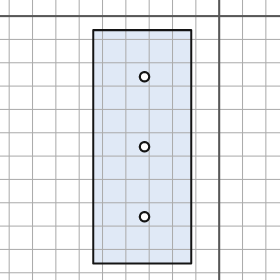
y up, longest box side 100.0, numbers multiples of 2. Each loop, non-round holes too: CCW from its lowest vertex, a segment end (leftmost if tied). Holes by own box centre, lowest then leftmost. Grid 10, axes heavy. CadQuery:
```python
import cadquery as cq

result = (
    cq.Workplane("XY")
    .moveTo(-54.0, -106.0)
    .lineTo(-12.0, -106.0)
    .lineTo(-12.0, -6.0)
    .lineTo(-54.0, -6.0)
    .close()
    .moveTo(-32.0, -86.0)
    .circle(2.0)
    .moveTo(-32.0, -56.0)
    .circle(2.0)
    .moveTo(-32.0, -26.0)
    .circle(2.0)
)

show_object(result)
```